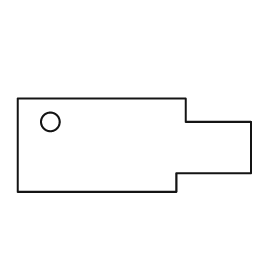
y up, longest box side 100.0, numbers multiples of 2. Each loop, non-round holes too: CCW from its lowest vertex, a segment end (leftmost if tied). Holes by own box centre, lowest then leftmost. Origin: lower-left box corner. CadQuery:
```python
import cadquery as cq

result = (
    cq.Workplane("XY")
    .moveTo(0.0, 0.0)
    .lineTo(68.0, 0.0)
    .lineTo(68.0, 8.0)
    .lineTo(100.0, 8.0)
    .lineTo(100.0, 30.0)
    .lineTo(72.0, 30.0)
    .lineTo(72.0, 40.0)
    .lineTo(0.0, 40.0)
    .close()
    .moveTo(14.0, 30.0)
    .circle(4.0)
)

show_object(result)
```